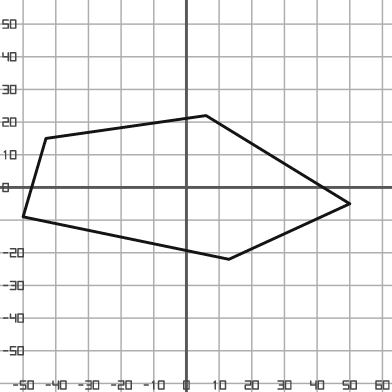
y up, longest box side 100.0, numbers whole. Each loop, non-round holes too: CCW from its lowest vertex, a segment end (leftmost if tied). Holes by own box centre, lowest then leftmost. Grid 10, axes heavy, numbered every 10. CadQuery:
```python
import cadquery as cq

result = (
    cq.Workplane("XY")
    .moveTo(13.0, -22.0)
    .lineTo(50.0, -5.0)
    .lineTo(6.0, 22.0)
    .lineTo(-43.0, 15.0)
    .lineTo(-50.0, -9.0)
    .close()
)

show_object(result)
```